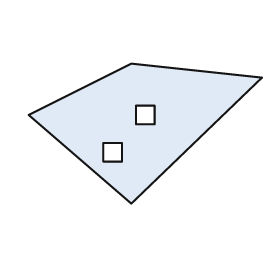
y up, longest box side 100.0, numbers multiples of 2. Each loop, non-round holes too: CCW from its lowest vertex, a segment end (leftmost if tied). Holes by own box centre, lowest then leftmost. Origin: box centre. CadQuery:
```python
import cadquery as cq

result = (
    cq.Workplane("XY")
    .moveTo(-6.0, -30.0)
    .lineTo(50.0, 24.0)
    .lineTo(-6.0, 30.0)
    .lineTo(-50.0, 8.0)
    .close()
    .moveTo(-18.0, -12.0)
    .lineTo(-10.0, -12.0)
    .lineTo(-10.0, -4.0)
    .lineTo(-18.0, -4.0)
    .close()
    .moveTo(-4.0, 4.0)
    .lineTo(4.0, 4.0)
    .lineTo(4.0, 12.0)
    .lineTo(-4.0, 12.0)
    .close()
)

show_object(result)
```